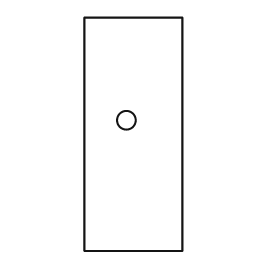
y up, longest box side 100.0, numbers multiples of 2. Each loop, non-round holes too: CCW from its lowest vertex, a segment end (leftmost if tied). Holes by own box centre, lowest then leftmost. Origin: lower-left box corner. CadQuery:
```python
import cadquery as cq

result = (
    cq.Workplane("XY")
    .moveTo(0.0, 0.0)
    .lineTo(42.0, 0.0)
    .lineTo(42.0, 100.0)
    .lineTo(0.0, 100.0)
    .close()
    .moveTo(18.0, 56.0)
    .circle(4.0)
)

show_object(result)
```